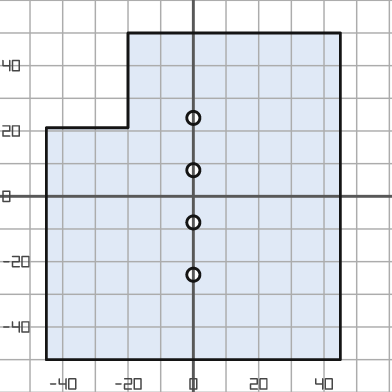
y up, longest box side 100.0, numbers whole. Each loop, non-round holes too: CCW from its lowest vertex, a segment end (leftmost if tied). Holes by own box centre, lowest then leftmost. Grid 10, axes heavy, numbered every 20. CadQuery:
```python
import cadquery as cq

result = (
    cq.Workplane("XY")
    .moveTo(-45.0, -50.0)
    .lineTo(45.0, -50.0)
    .lineTo(45.0, 50.0)
    .lineTo(-20.0, 50.0)
    .lineTo(-20.0, 21.0)
    .lineTo(-45.0, 21.0)
    .close()
    .moveTo(0.0, -24.0)
    .circle(2.0)
    .moveTo(0.0, -8.0)
    .circle(2.0)
    .moveTo(0.0, 8.0)
    .circle(2.0)
    .moveTo(0.0, 24.0)
    .circle(2.0)
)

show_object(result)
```